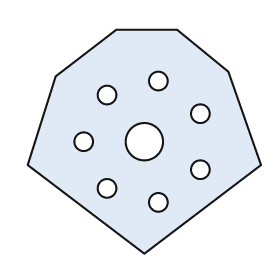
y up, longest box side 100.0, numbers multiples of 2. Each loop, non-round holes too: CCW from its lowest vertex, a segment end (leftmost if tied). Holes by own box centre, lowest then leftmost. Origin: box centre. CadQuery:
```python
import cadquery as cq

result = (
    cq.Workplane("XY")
    .moveTo(0.0, -48.0)
    .lineTo(50.0, -10.0)
    .lineTo(36.0, 30.0)
    .lineTo(14.0, 48.0)
    .lineTo(-12.0, 48.0)
    .lineTo(-38.0, 28.0)
    .lineTo(-50.0, -10.0)
    .close()
    .moveTo(6.0, -26.0)
    .circle(4.0)
    .moveTo(-16.0, -20.0)
    .circle(4.0)
    .moveTo(24.0, -12.0)
    .circle(4.0)
    .moveTo(-26.0, 0.0)
    .circle(4.0)
    .moveTo(0.0, 0.0)
    .circle(8.0)
    .moveTo(24.0, 12.0)
    .circle(4.0)
    .moveTo(-16.0, 20.0)
    .circle(4.0)
    .moveTo(6.0, 26.0)
    .circle(4.0)
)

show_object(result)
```